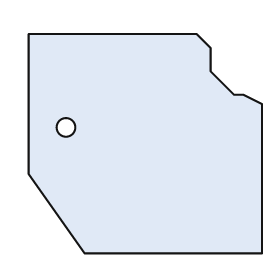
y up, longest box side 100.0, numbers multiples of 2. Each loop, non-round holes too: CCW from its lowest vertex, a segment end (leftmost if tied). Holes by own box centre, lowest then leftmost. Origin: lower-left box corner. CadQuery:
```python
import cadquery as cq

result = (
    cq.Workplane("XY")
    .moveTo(24.0, 0.0)
    .lineTo(100.0, 0.0)
    .lineTo(100.0, 64.0)
    .lineTo(92.0, 68.0)
    .lineTo(88.0, 68.0)
    .lineTo(78.0, 78.0)
    .lineTo(78.0, 88.0)
    .lineTo(72.0, 94.0)
    .lineTo(0.0, 94.0)
    .lineTo(0.0, 34.0)
    .close()
    .moveTo(16.0, 54.0)
    .circle(4.0)
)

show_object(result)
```